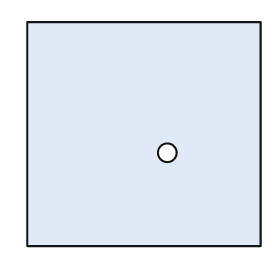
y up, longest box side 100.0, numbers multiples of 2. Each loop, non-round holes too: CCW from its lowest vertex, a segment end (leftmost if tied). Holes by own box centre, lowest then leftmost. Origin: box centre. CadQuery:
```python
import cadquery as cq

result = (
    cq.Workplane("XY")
    .moveTo(-50.0, -48.0)
    .lineTo(50.0, -48.0)
    .lineTo(50.0, 48.0)
    .lineTo(-50.0, 48.0)
    .close()
    .moveTo(10.0, -8.0)
    .circle(4.0)
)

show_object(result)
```